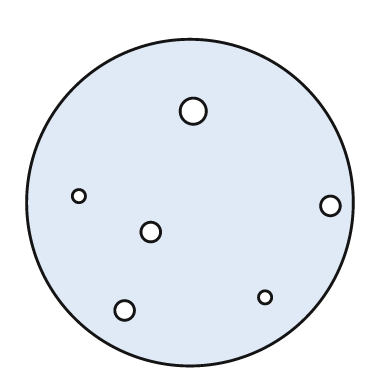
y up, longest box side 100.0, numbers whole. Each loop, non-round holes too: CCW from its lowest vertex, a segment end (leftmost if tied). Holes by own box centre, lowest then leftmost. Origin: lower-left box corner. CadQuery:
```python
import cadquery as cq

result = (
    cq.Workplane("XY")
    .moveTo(50.0, 50.0)
    .circle(50.0)
    .moveTo(30.0, 17.0)
    .circle(3.0)
    .moveTo(73.0, 21.0)
    .circle(2.0)
    .moveTo(38.0, 41.0)
    .circle(3.0)
    .moveTo(93.0, 49.0)
    .circle(3.0)
    .moveTo(16.0, 52.0)
    .circle(2.0)
    .moveTo(51.0, 78.0)
    .circle(4.0)
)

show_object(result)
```